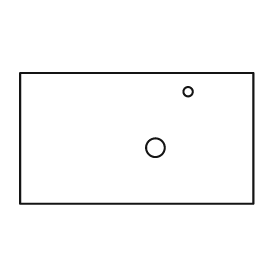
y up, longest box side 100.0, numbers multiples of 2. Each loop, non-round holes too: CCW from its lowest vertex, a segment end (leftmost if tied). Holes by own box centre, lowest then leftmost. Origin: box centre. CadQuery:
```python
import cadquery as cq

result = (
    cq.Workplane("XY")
    .moveTo(-50.0, -28.0)
    .lineTo(50.0, -28.0)
    .lineTo(50.0, 28.0)
    .lineTo(-50.0, 28.0)
    .close()
    .moveTo(8.0, -4.0)
    .circle(4.0)
    .moveTo(22.0, 20.0)
    .circle(2.0)
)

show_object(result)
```